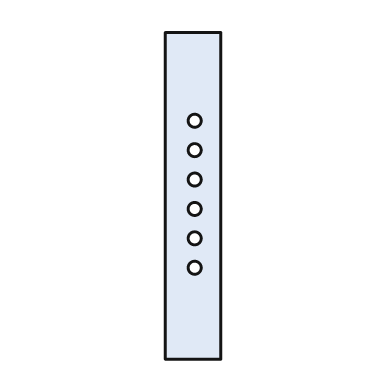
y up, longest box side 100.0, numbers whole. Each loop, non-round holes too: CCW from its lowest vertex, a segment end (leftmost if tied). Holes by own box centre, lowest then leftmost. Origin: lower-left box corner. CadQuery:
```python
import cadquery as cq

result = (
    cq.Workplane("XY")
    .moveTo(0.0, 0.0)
    .lineTo(17.0, 0.0)
    .lineTo(17.0, 100.0)
    .lineTo(0.0, 100.0)
    .close()
    .moveTo(9.0, 28.0)
    .circle(2.0)
    .moveTo(9.0, 37.0)
    .circle(2.0)
    .moveTo(9.0, 46.0)
    .circle(2.0)
    .moveTo(9.0, 55.0)
    .circle(2.0)
    .moveTo(9.0, 64.0)
    .circle(2.0)
    .moveTo(9.0, 73.0)
    .circle(2.0)
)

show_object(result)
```